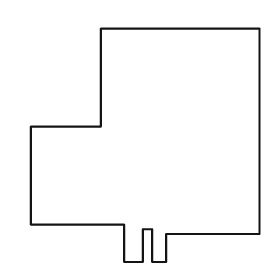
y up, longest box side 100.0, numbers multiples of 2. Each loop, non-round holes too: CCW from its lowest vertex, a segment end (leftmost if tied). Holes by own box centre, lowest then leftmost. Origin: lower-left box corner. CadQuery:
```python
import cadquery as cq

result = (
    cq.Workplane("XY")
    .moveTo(40.0, 0.0)
    .lineTo(48.0, 0.0)
    .lineTo(48.0, 14.0)
    .lineTo(52.0, 14.0)
    .lineTo(52.0, 0.0)
    .lineTo(58.0, 0.0)
    .lineTo(58.0, 12.0)
    .lineTo(98.0, 12.0)
    .lineTo(98.0, 100.0)
    .lineTo(30.0, 100.0)
    .lineTo(30.0, 58.0)
    .lineTo(0.0, 58.0)
    .lineTo(0.0, 16.0)
    .lineTo(40.0, 16.0)
    .close()
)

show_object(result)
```